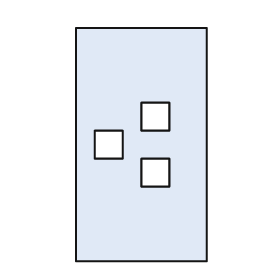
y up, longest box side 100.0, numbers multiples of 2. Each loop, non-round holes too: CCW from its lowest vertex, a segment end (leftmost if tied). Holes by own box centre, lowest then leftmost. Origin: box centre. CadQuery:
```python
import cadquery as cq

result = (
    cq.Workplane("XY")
    .moveTo(-28.0, -50.0)
    .lineTo(28.0, -50.0)
    .lineTo(28.0, 50.0)
    .lineTo(-28.0, 50.0)
    .close()
    .moveTo(0.0, -18.0)
    .lineTo(12.0, -18.0)
    .lineTo(12.0, -6.0)
    .lineTo(0.0, -6.0)
    .close()
    .moveTo(-20.0, -6.0)
    .lineTo(-8.0, -6.0)
    .lineTo(-8.0, 6.0)
    .lineTo(-20.0, 6.0)
    .close()
    .moveTo(0.0, 6.0)
    .lineTo(12.0, 6.0)
    .lineTo(12.0, 18.0)
    .lineTo(0.0, 18.0)
    .close()
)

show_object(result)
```